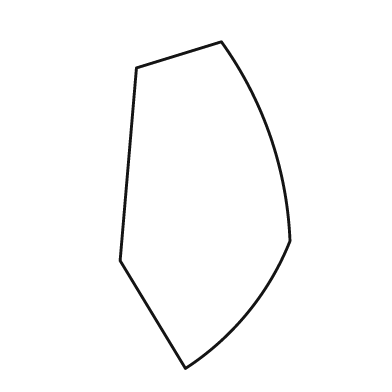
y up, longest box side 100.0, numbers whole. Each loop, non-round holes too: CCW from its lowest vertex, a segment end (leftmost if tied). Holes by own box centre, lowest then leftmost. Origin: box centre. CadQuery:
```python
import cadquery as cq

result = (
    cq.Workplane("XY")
    .moveTo(-6.0, -50.0)
    .threePointArc((13.0, -33.0), (26.0, -11.0))
    .threePointArc((20.0, 21.0), (5.0, 50.0))
    .lineTo(-21.0, 42.0)
    .lineTo(-26.0, -17.0)
    .close()
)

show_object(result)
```